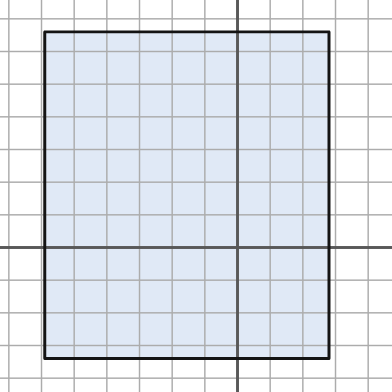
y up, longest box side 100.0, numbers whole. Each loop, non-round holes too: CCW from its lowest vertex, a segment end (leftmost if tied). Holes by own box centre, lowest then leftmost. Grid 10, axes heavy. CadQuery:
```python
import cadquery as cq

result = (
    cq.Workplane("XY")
    .moveTo(-59.0, -34.0)
    .lineTo(28.0, -34.0)
    .lineTo(28.0, 66.0)
    .lineTo(-59.0, 66.0)
    .close()
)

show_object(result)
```